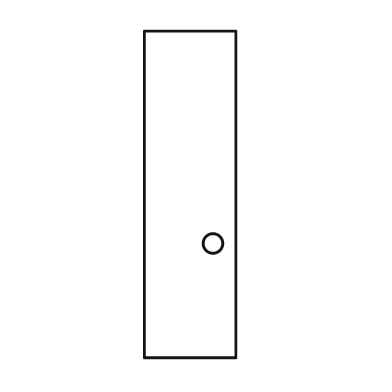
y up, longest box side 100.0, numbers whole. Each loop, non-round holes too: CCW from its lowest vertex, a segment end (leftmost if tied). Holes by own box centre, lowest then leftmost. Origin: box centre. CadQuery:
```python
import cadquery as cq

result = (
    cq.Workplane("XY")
    .moveTo(-14.0, -50.0)
    .lineTo(14.0, -50.0)
    .lineTo(14.0, 50.0)
    .lineTo(-14.0, 50.0)
    .close()
    .moveTo(7.0, -15.0)
    .circle(3.0)
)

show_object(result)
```